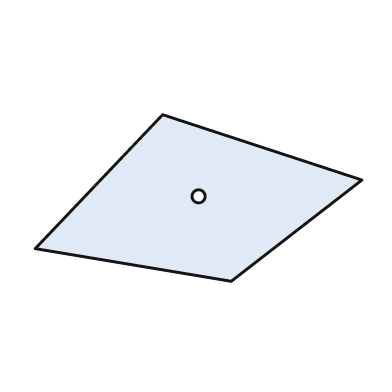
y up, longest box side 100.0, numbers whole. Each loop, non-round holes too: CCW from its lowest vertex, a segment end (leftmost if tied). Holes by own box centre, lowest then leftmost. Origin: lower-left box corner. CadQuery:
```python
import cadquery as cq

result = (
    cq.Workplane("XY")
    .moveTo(60.0, 0.0)
    .lineTo(100.0, 31.0)
    .lineTo(39.0, 51.0)
    .lineTo(0.0, 10.0)
    .close()
    .moveTo(50.0, 26.0)
    .circle(2.0)
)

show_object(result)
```